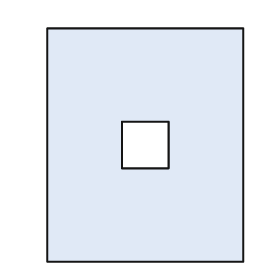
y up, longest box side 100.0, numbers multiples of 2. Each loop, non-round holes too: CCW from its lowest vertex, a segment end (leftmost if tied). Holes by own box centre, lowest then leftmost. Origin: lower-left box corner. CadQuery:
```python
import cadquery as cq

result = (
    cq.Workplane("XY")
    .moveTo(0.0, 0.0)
    .lineTo(84.0, 0.0)
    .lineTo(84.0, 100.0)
    .lineTo(0.0, 100.0)
    .close()
    .moveTo(32.0, 40.0)
    .lineTo(52.0, 40.0)
    .lineTo(52.0, 60.0)
    .lineTo(32.0, 60.0)
    .close()
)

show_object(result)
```